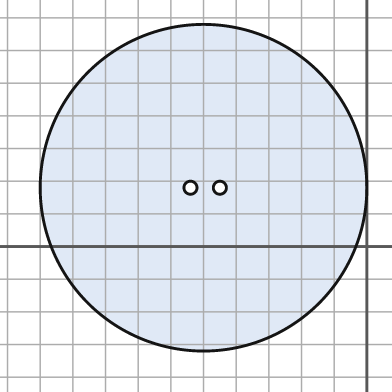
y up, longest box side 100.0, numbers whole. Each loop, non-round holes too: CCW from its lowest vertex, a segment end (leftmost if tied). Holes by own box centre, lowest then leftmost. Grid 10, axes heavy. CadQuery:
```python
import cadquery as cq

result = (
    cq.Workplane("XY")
    .moveTo(-50.0, 18.0)
    .circle(50.0)
    .moveTo(-54.0, 18.0)
    .circle(2.0)
    .moveTo(-45.0, 18.0)
    .circle(2.0)
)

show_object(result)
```